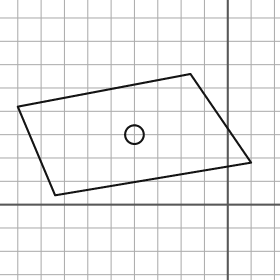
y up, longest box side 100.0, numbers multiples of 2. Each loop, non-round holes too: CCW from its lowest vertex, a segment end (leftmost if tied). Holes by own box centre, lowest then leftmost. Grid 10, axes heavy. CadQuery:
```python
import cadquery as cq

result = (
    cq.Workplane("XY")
    .moveTo(-74.0, 4.0)
    .lineTo(10.0, 18.0)
    .lineTo(-16.0, 56.0)
    .lineTo(-90.0, 42.0)
    .close()
    .moveTo(-40.0, 30.0)
    .circle(4.0)
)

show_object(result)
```